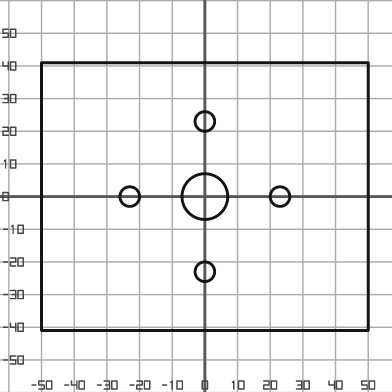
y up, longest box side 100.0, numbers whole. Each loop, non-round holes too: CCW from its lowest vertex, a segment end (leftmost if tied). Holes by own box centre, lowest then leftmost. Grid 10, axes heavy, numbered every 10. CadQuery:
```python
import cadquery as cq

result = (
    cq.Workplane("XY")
    .moveTo(-50.0, -41.0)
    .lineTo(50.0, -41.0)
    .lineTo(50.0, 41.0)
    .lineTo(-50.0, 41.0)
    .close()
    .moveTo(0.0, -23.0)
    .circle(3.0)
    .moveTo(-23.0, 0.0)
    .circle(3.0)
    .moveTo(0.0, 0.0)
    .circle(7.0)
    .moveTo(23.0, 0.0)
    .circle(3.0)
    .moveTo(0.0, 23.0)
    .circle(3.0)
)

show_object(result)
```